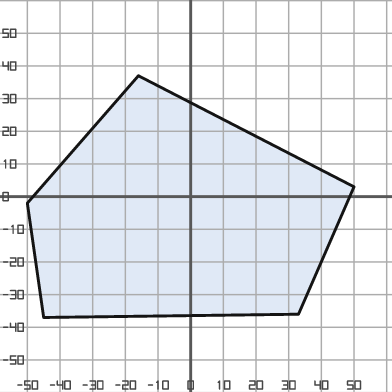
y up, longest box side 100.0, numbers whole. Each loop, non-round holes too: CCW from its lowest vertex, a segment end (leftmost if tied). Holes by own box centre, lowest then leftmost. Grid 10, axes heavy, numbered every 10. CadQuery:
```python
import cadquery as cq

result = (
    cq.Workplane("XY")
    .moveTo(-45.0, -37.0)
    .lineTo(33.0, -36.0)
    .lineTo(50.0, 3.0)
    .lineTo(-16.0, 37.0)
    .lineTo(-50.0, -2.0)
    .close()
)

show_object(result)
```